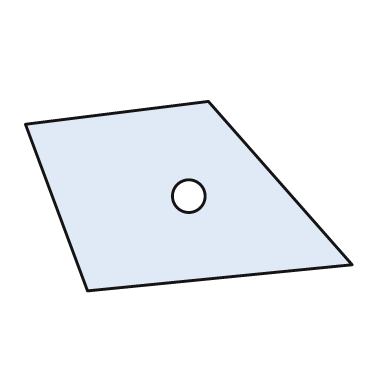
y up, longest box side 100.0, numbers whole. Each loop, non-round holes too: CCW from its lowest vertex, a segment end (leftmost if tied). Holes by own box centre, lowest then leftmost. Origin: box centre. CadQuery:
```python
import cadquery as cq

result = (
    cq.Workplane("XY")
    .moveTo(-31.0, -29.0)
    .lineTo(50.0, -21.0)
    .lineTo(6.0, 29.0)
    .lineTo(-50.0, 22.0)
    .close()
    .moveTo(0.0, 0.0)
    .circle(5.0)
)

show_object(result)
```